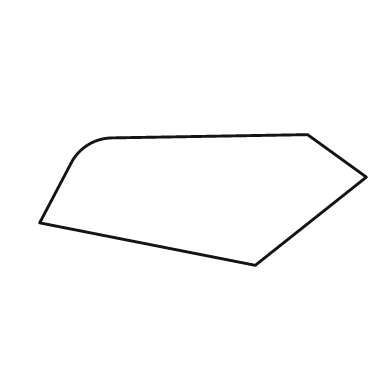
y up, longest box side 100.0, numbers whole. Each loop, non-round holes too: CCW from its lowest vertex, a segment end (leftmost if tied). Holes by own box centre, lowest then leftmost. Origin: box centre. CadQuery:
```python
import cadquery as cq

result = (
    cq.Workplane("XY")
    .moveTo(16.0, -20.0)
    .lineTo(50.0, 7.0)
    .lineTo(32.0, 20.0)
    .lineTo(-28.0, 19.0)
    .threePointArc((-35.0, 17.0), (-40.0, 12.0))
    .lineTo(-50.0, -7.0)
    .close()
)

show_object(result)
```